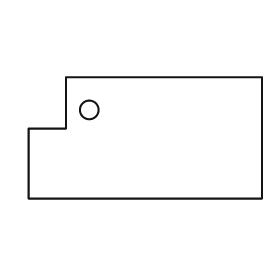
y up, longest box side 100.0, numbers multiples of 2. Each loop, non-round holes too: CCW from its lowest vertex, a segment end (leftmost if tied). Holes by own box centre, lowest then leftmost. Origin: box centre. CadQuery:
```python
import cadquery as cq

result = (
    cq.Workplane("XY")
    .moveTo(-50.0, -26.0)
    .lineTo(50.0, -26.0)
    .lineTo(50.0, 26.0)
    .lineTo(-34.0, 26.0)
    .lineTo(-34.0, 4.0)
    .lineTo(-50.0, 4.0)
    .close()
    .moveTo(-24.0, 12.0)
    .circle(4.0)
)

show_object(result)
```